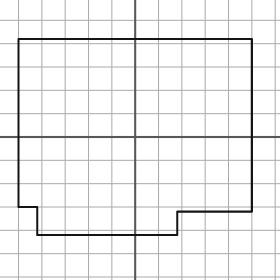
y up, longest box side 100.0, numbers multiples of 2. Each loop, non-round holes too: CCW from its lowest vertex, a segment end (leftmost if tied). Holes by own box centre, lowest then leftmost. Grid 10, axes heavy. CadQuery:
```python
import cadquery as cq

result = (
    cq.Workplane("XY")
    .moveTo(-42.0, -42.0)
    .lineTo(18.0, -42.0)
    .lineTo(18.0, -32.0)
    .lineTo(50.0, -32.0)
    .lineTo(50.0, 42.0)
    .lineTo(-50.0, 42.0)
    .lineTo(-50.0, -30.0)
    .lineTo(-42.0, -30.0)
    .close()
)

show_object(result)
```